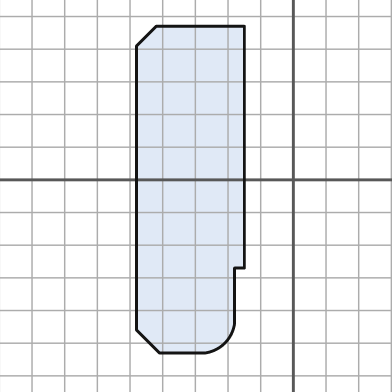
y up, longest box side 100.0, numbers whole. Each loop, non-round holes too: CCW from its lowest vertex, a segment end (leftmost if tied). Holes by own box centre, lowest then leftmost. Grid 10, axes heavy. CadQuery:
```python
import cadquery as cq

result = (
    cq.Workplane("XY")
    .moveTo(-41.0, -53.0)
    .lineTo(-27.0, -53.0)
    .threePointArc((-21.0, -50.0), (-18.0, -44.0))
    .lineTo(-18.0, -27.0)
    .lineTo(-15.0, -27.0)
    .lineTo(-15.0, 47.0)
    .lineTo(-42.0, 47.0)
    .lineTo(-48.0, 41.0)
    .lineTo(-48.0, -46.0)
    .close()
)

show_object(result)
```